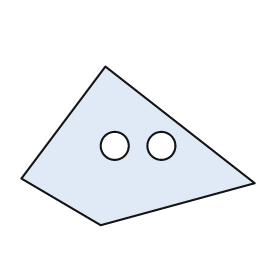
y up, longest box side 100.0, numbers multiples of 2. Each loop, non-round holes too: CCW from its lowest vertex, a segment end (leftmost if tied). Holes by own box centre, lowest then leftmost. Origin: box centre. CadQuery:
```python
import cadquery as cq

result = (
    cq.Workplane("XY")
    .moveTo(-16.0, -34.0)
    .lineTo(50.0, -16.0)
    .lineTo(-14.0, 34.0)
    .lineTo(-50.0, -14.0)
    .close()
    .moveTo(-10.0, 0.0)
    .circle(6.0)
    .moveTo(10.0, 0.0)
    .circle(6.0)
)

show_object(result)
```